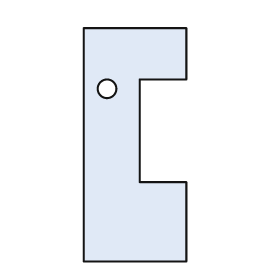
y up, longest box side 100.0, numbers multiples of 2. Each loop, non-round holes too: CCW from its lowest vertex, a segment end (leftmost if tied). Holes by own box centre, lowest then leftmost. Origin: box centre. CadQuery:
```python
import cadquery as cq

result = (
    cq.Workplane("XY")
    .moveTo(-22.0, -50.0)
    .lineTo(22.0, -50.0)
    .lineTo(22.0, -16.0)
    .lineTo(2.0, -16.0)
    .lineTo(2.0, 28.0)
    .lineTo(22.0, 28.0)
    .lineTo(22.0, 50.0)
    .lineTo(-22.0, 50.0)
    .close()
    .moveTo(-12.0, 24.0)
    .circle(4.0)
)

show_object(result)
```